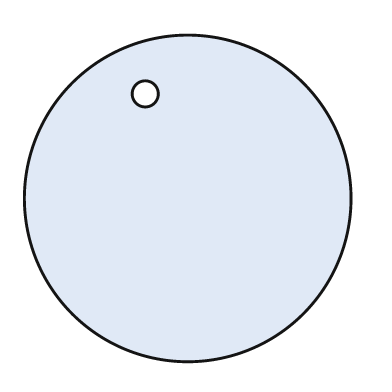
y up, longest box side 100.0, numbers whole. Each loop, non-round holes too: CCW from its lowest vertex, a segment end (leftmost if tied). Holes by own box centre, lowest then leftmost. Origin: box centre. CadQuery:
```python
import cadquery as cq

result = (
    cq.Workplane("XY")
    .moveTo(0.0, 0.0)
    .circle(50.0)
    .moveTo(-13.0, 32.0)
    .circle(4.0)
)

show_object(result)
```